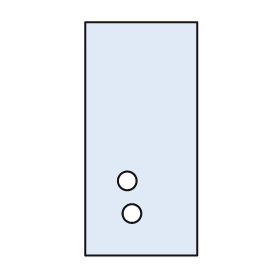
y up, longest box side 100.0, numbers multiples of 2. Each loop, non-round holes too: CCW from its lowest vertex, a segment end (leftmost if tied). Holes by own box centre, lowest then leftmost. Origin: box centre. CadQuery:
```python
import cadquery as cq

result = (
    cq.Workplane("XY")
    .moveTo(-24.0, -50.0)
    .lineTo(24.0, -50.0)
    .lineTo(24.0, 50.0)
    .lineTo(-24.0, 50.0)
    .close()
    .moveTo(-4.0, -32.0)
    .circle(4.0)
    .moveTo(-6.0, -18.0)
    .circle(4.0)
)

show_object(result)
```